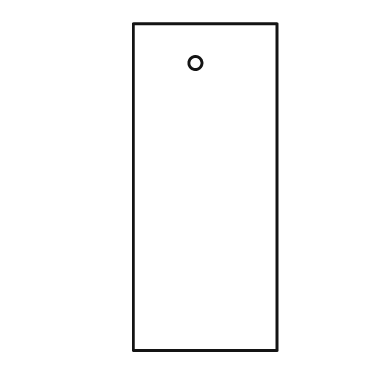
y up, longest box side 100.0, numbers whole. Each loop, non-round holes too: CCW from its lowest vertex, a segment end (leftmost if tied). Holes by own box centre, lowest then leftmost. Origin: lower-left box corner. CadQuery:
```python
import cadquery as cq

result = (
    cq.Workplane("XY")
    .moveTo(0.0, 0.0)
    .lineTo(44.0, 0.0)
    .lineTo(44.0, 100.0)
    .lineTo(0.0, 100.0)
    .close()
    .moveTo(19.0, 88.0)
    .circle(2.0)
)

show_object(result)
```